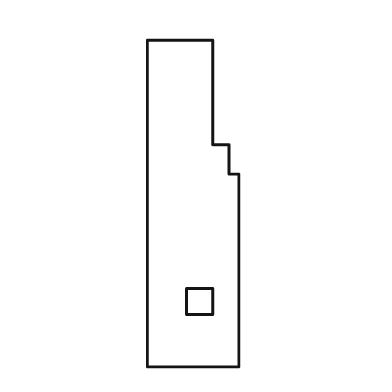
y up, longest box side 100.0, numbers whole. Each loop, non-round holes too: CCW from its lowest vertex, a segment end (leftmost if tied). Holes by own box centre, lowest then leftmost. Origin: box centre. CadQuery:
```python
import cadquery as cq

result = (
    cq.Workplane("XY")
    .moveTo(-14.0, -50.0)
    .lineTo(14.0, -50.0)
    .lineTo(14.0, 9.0)
    .lineTo(11.0, 9.0)
    .lineTo(11.0, 18.0)
    .lineTo(6.0, 18.0)
    .lineTo(6.0, 50.0)
    .lineTo(-14.0, 50.0)
    .close()
    .moveTo(-2.0, -34.0)
    .lineTo(6.0, -34.0)
    .lineTo(6.0, -26.0)
    .lineTo(-2.0, -26.0)
    .close()
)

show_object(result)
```